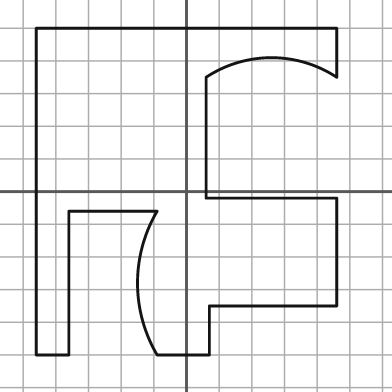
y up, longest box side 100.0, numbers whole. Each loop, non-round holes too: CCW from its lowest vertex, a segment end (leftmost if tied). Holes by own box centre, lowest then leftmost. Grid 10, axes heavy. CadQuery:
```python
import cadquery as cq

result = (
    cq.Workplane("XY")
    .moveTo(-46.0, -50.0)
    .lineTo(-36.0, -50.0)
    .lineTo(-36.0, -6.0)
    .lineTo(-9.0, -6.0)
    .threePointArc((-15.0, -28.0), (-9.0, -50.0))
    .lineTo(7.0, -50.0)
    .lineTo(7.0, -35.0)
    .lineTo(46.0, -35.0)
    .lineTo(46.0, -2.0)
    .lineTo(6.0, -2.0)
    .lineTo(6.0, 35.0)
    .threePointArc((26.0, 41.0), (46.0, 35.0))
    .lineTo(46.0, 50.0)
    .lineTo(-46.0, 50.0)
    .close()
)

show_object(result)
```